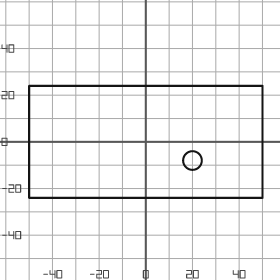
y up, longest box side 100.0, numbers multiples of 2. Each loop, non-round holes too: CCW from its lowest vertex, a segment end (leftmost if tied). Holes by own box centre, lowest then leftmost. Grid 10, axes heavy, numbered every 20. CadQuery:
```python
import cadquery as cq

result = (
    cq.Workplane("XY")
    .moveTo(-50.0, -24.0)
    .lineTo(50.0, -24.0)
    .lineTo(50.0, 24.0)
    .lineTo(-50.0, 24.0)
    .close()
    .moveTo(20.0, -8.0)
    .circle(4.0)
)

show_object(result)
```